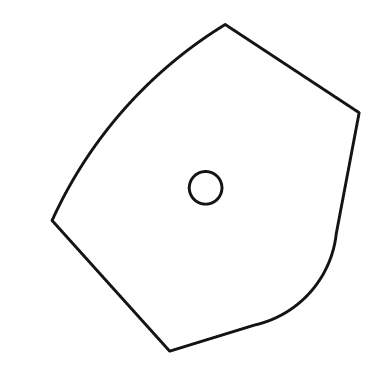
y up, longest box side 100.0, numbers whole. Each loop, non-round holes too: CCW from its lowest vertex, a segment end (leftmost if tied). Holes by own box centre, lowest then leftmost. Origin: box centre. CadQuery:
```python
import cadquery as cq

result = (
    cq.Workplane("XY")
    .moveTo(-11.0, -50.0)
    .lineTo(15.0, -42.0)
    .threePointArc((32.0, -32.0), (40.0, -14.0))
    .lineTo(47.0, 23.0)
    .lineTo(6.0, 50.0)
    .threePointArc((-25.0, 24.0), (-47.0, -10.0))
    .close()
    .moveTo(0.0, 0.0)
    .circle(5.0)
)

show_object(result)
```